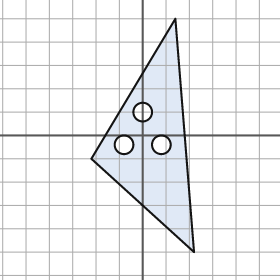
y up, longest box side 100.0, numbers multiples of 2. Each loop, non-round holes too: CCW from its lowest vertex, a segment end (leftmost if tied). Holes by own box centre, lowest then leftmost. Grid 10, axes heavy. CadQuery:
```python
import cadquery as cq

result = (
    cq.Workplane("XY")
    .moveTo(22.0, -50.0)
    .lineTo(14.0, 50.0)
    .lineTo(-22.0, -10.0)
    .close()
    .moveTo(-8.0, -4.0)
    .circle(4.0)
    .moveTo(8.0, -4.0)
    .circle(4.0)
    .moveTo(0.0, 10.0)
    .circle(4.0)
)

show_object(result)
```